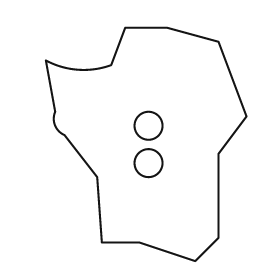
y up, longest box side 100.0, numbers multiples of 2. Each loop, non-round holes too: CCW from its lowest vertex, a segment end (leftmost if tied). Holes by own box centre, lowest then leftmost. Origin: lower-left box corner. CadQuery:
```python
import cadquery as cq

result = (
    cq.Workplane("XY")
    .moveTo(64.0, 0.0)
    .lineTo(74.0, 10.0)
    .lineTo(74.0, 46.0)
    .lineTo(86.0, 62.0)
    .lineTo(74.0, 94.0)
    .lineTo(52.0, 100.0)
    .lineTo(34.0, 100.0)
    .lineTo(28.0, 84.0)
    .threePointArc((14.0, 82.0), (0.0, 86.0))
    .lineTo(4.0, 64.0)
    .threePointArc((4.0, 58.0), (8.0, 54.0))
    .lineTo(22.0, 36.0)
    .lineTo(24.0, 8.0)
    .lineTo(40.0, 8.0)
    .close()
    .moveTo(44.0, 42.0)
    .circle(6.0)
    .moveTo(44.0, 58.0)
    .circle(6.0)
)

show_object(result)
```